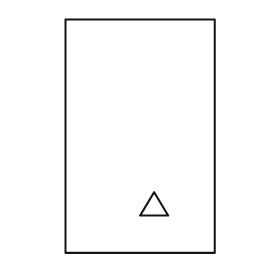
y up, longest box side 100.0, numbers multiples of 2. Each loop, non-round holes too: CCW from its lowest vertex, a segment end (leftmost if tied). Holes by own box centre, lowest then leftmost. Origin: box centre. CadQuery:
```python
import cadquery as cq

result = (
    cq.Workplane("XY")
    .moveTo(-32.0, -50.0)
    .lineTo(32.0, -50.0)
    .lineTo(32.0, 50.0)
    .lineTo(-32.0, 50.0)
    .close()
    .moveTo(0.0, -34.0)
    .lineTo(12.0, -34.0)
    .lineTo(6.0, -24.0)
    .close()
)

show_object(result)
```